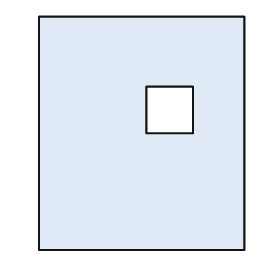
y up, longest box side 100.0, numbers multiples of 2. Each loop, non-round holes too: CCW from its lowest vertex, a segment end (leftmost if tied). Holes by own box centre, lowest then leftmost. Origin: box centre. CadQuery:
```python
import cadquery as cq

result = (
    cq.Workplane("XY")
    .moveTo(-44.0, -50.0)
    .lineTo(44.0, -50.0)
    .lineTo(44.0, 50.0)
    .lineTo(-44.0, 50.0)
    .close()
    .moveTo(2.0, 0.0)
    .lineTo(22.0, 0.0)
    .lineTo(22.0, 20.0)
    .lineTo(2.0, 20.0)
    .close()
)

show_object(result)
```